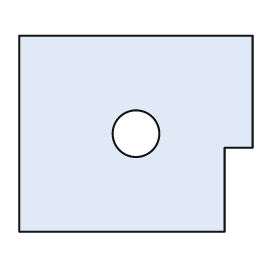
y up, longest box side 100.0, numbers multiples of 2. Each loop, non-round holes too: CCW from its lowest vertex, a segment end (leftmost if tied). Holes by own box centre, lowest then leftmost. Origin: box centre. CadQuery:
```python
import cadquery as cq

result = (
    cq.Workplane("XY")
    .moveTo(-50.0, -42.0)
    .lineTo(38.0, -42.0)
    .lineTo(38.0, -6.0)
    .lineTo(50.0, -6.0)
    .lineTo(50.0, 42.0)
    .lineTo(-50.0, 42.0)
    .close()
    .moveTo(0.0, 0.0)
    .circle(10.0)
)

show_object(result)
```